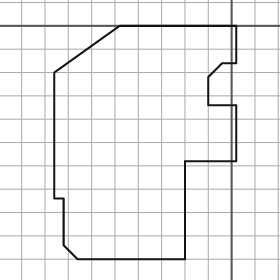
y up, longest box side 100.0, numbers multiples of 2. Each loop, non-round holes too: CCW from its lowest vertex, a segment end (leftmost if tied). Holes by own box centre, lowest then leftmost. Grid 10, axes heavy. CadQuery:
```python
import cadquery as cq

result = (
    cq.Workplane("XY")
    .moveTo(-66.0, -100.0)
    .lineTo(-20.0, -100.0)
    .lineTo(-20.0, -58.0)
    .lineTo(2.0, -58.0)
    .lineTo(2.0, -34.0)
    .lineTo(-10.0, -34.0)
    .lineTo(-10.0, -22.0)
    .lineTo(-4.0, -16.0)
    .lineTo(2.0, -16.0)
    .lineTo(2.0, 0.0)
    .lineTo(-48.0, 0.0)
    .lineTo(-76.0, -20.0)
    .lineTo(-76.0, -74.0)
    .lineTo(-72.0, -74.0)
    .lineTo(-72.0, -94.0)
    .close()
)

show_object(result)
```